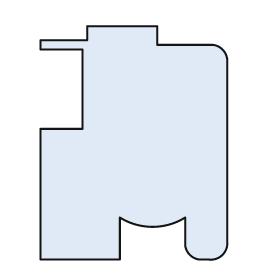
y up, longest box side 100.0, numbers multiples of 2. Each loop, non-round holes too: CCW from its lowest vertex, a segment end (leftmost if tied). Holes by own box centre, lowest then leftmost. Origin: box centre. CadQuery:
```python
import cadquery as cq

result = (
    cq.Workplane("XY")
    .moveTo(-40.0, -50.0)
    .lineTo(-6.0, -50.0)
    .lineTo(-6.0, -32.0)
    .threePointArc((8.0, -36.0), (22.0, -32.0))
    .lineTo(22.0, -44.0)
    .threePointArc((24.0, -48.0), (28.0, -50.0))
    .lineTo(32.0, -50.0)
    .threePointArc((38.0, -48.0), (40.0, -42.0))
    .lineTo(40.0, 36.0)
    .threePointArc((38.0, 40.0), (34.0, 42.0))
    .lineTo(10.0, 42.0)
    .lineTo(10.0, 50.0)
    .lineTo(-20.0, 50.0)
    .lineTo(-20.0, 44.0)
    .lineTo(-40.0, 44.0)
    .lineTo(-40.0, 40.0)
    .lineTo(-22.0, 40.0)
    .lineTo(-22.0, 6.0)
    .lineTo(-40.0, 6.0)
    .close()
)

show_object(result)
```